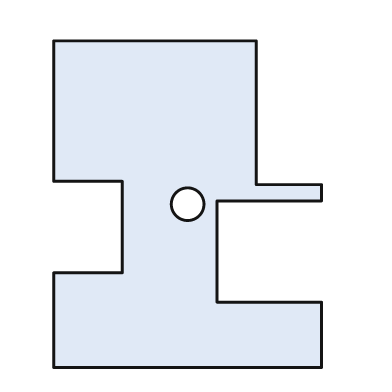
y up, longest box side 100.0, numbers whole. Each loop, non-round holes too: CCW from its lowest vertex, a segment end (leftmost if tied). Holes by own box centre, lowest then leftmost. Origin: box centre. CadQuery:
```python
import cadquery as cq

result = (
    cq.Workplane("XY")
    .moveTo(-41.0, -50.0)
    .lineTo(41.0, -50.0)
    .lineTo(41.0, -30.0)
    .lineTo(9.0, -30.0)
    .lineTo(9.0, 1.0)
    .lineTo(41.0, 1.0)
    .lineTo(41.0, 6.0)
    .lineTo(21.0, 6.0)
    .lineTo(21.0, 50.0)
    .lineTo(-41.0, 50.0)
    .lineTo(-41.0, 7.0)
    .lineTo(-20.0, 7.0)
    .lineTo(-20.0, -21.0)
    .lineTo(-41.0, -21.0)
    .close()
    .moveTo(0.0, 0.0)
    .circle(5.0)
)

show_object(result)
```